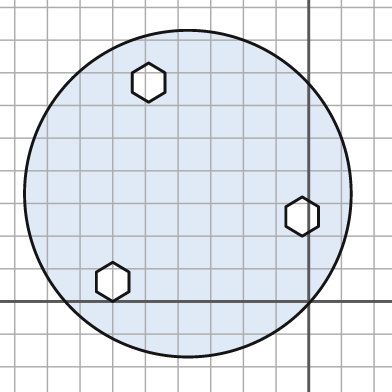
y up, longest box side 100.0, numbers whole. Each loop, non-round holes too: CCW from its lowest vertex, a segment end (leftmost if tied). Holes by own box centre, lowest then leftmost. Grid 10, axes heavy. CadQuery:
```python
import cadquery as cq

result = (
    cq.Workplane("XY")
    .moveTo(-37.0, 33.0)
    .circle(50.0)
    .moveTo(-60.0, 0.0)
    .lineTo(-55.0, 3.0)
    .lineTo(-55.0, 9.0)
    .lineTo(-60.0, 12.0)
    .lineTo(-65.0, 9.0)
    .lineTo(-65.0, 3.0)
    .close()
    .moveTo(-2.0, 20.0)
    .lineTo(3.0, 23.0)
    .lineTo(3.0, 29.0)
    .lineTo(-2.0, 32.0)
    .lineTo(-7.0, 29.0)
    .lineTo(-7.0, 23.0)
    .close()
    .moveTo(-49.0, 61.0)
    .lineTo(-44.0, 64.0)
    .lineTo(-44.0, 70.0)
    .lineTo(-49.0, 73.0)
    .lineTo(-54.0, 70.0)
    .lineTo(-54.0, 64.0)
    .close()
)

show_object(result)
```